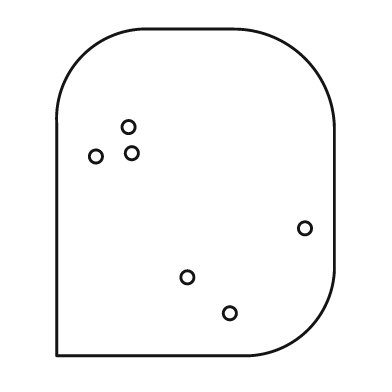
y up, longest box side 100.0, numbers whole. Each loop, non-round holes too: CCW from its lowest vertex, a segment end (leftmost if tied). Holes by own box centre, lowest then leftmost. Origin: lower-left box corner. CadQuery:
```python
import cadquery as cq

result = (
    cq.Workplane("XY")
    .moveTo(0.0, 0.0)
    .lineTo(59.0, 0.0)
    .threePointArc((77.0, 8.0), (85.0, 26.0))
    .lineTo(85.0, 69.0)
    .threePointArc((76.0, 91.0), (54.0, 100.0))
    .lineTo(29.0, 100.0)
    .threePointArc((8.0, 92.0), (0.0, 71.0))
    .close()
    .moveTo(53.0, 13.0)
    .circle(2.0)
    .moveTo(40.0, 24.0)
    .circle(2.0)
    .moveTo(76.0, 39.0)
    .circle(2.0)
    .moveTo(12.0, 61.0)
    .circle(2.0)
    .moveTo(23.0, 62.0)
    .circle(2.0)
    .moveTo(22.0, 70.0)
    .circle(2.0)
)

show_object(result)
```